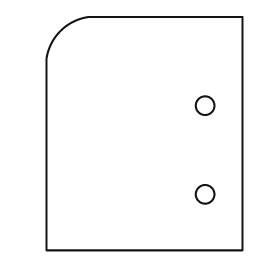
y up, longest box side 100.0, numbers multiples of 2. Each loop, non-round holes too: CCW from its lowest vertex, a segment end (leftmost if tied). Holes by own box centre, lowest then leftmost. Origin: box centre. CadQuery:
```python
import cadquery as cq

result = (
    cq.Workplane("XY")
    .moveTo(-42.0, -50.0)
    .lineTo(42.0, -50.0)
    .lineTo(42.0, 50.0)
    .lineTo(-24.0, 50.0)
    .threePointArc((-36.0, 44.0), (-42.0, 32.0))
    .close()
    .moveTo(26.0, -26.0)
    .circle(4.0)
    .moveTo(26.0, 12.0)
    .circle(4.0)
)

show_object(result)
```